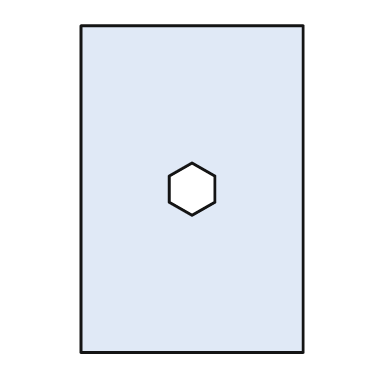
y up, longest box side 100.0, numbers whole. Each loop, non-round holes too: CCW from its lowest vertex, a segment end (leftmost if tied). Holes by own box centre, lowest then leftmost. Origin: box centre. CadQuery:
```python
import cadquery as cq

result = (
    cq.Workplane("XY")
    .moveTo(-34.0, -50.0)
    .lineTo(34.0, -50.0)
    .lineTo(34.0, 50.0)
    .lineTo(-34.0, 50.0)
    .close()
    .moveTo(0.0, -8.0)
    .lineTo(7.0, -4.0)
    .lineTo(7.0, 4.0)
    .lineTo(0.0, 8.0)
    .lineTo(-7.0, 4.0)
    .lineTo(-7.0, -4.0)
    .close()
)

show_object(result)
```